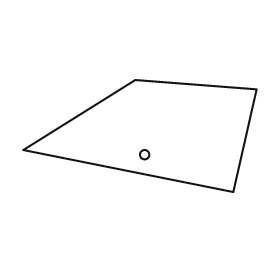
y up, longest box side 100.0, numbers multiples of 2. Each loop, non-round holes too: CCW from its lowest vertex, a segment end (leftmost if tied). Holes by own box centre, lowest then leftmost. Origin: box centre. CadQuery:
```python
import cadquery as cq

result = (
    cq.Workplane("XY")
    .moveTo(40.0, -24.0)
    .lineTo(50.0, 20.0)
    .lineTo(-2.0, 24.0)
    .lineTo(-50.0, -6.0)
    .close()
    .moveTo(2.0, -8.0)
    .circle(2.0)
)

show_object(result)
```